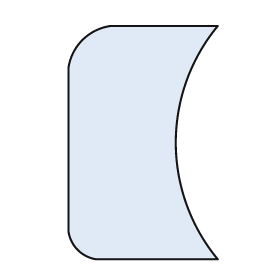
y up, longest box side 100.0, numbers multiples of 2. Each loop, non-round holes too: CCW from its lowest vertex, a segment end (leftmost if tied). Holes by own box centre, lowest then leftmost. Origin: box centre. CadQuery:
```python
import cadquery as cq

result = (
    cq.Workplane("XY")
    .moveTo(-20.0, -50.0)
    .lineTo(32.0, -50.0)
    .threePointArc((14.0, 0.0), (32.0, 50.0))
    .lineTo(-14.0, 50.0)
    .threePointArc((-26.0, 44.0), (-32.0, 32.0))
    .lineTo(-32.0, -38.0)
    .threePointArc((-28.0, -46.0), (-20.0, -50.0))
    .close()
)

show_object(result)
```